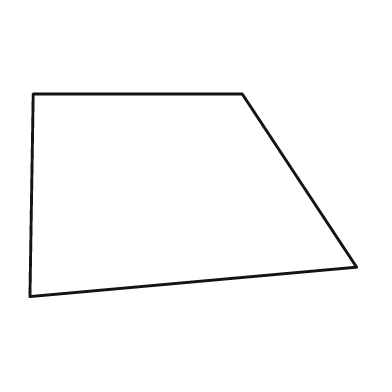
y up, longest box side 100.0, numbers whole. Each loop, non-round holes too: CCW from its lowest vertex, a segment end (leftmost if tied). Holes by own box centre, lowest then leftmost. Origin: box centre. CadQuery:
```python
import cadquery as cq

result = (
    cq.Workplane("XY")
    .moveTo(-50.0, -31.0)
    .lineTo(50.0, -22.0)
    .lineTo(15.0, 31.0)
    .lineTo(-49.0, 31.0)
    .close()
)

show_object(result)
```